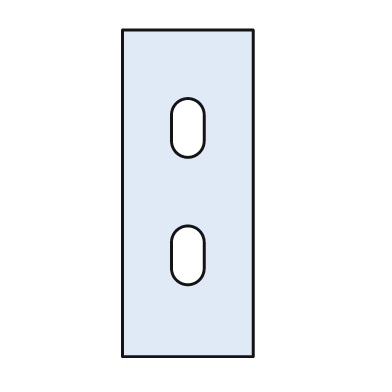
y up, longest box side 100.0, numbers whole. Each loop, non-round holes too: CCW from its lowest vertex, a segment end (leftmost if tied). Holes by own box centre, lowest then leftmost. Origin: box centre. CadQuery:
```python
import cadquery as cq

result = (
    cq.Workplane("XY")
    .moveTo(-20.0, -50.0)
    .lineTo(20.0, -50.0)
    .lineTo(20.0, 50.0)
    .lineTo(-20.0, 50.0)
    .close()
    .moveTo(-5.0, -23.0)
    .threePointArc((0.0, -28.0), (5.0, -23.0))
    .lineTo(5.0, -15.0)
    .threePointArc((0.0, -10.0), (-5.0, -15.0))
    .close()
    .moveTo(-5.0, 16.0)
    .threePointArc((0.0, 11.0), (5.0, 16.0))
    .lineTo(5.0, 24.0)
    .threePointArc((0.0, 29.0), (-5.0, 24.0))
    .close()
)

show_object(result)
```